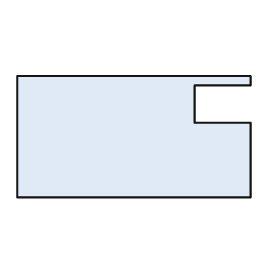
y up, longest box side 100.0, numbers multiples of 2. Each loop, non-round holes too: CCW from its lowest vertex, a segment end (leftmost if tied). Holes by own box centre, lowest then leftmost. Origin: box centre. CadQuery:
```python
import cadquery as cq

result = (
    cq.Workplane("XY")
    .moveTo(-50.0, -26.0)
    .lineTo(50.0, -26.0)
    .lineTo(50.0, 6.0)
    .lineTo(26.0, 6.0)
    .lineTo(26.0, 22.0)
    .lineTo(50.0, 22.0)
    .lineTo(50.0, 26.0)
    .lineTo(-50.0, 26.0)
    .close()
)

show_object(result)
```